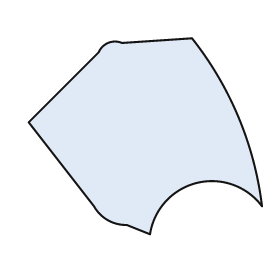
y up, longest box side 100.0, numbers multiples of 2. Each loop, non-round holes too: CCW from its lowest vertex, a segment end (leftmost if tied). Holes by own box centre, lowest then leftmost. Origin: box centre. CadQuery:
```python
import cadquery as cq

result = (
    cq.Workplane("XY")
    .moveTo(2.0, -42.0)
    .threePointArc((22.0, -20.0), (50.0, -30.0))
    .threePointArc((40.0, 8.0), (20.0, 42.0))
    .lineTo(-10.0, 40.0)
    .threePointArc((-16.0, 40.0), (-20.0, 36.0))
    .lineTo(-50.0, 6.0)
    .lineTo(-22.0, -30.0)
    .threePointArc((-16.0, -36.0), (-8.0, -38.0))
    .close()
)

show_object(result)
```